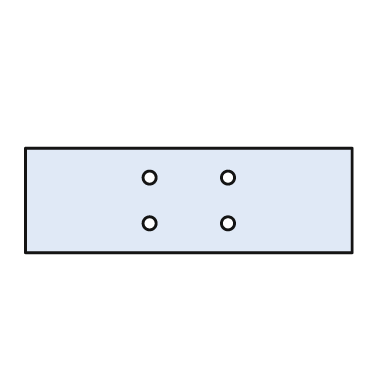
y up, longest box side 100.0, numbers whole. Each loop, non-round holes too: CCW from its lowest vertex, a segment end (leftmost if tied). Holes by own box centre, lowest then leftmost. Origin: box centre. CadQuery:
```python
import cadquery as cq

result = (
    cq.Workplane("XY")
    .moveTo(-50.0, -16.0)
    .lineTo(50.0, -16.0)
    .lineTo(50.0, 16.0)
    .lineTo(-50.0, 16.0)
    .close()
    .moveTo(-12.0, -7.0)
    .circle(2.0)
    .moveTo(12.0, -7.0)
    .circle(2.0)
    .moveTo(-12.0, 7.0)
    .circle(2.0)
    .moveTo(12.0, 7.0)
    .circle(2.0)
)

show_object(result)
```